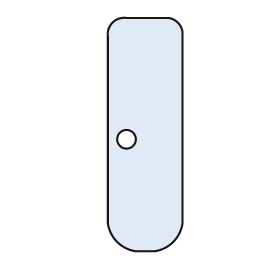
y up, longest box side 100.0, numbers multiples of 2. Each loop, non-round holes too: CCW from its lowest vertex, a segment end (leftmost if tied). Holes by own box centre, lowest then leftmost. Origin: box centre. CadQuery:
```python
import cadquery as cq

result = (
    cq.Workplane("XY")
    .moveTo(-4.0, -50.0)
    .lineTo(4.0, -50.0)
    .threePointArc((12.0, -46.0), (16.0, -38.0))
    .lineTo(16.0, 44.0)
    .threePointArc((14.0, 48.0), (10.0, 50.0))
    .lineTo(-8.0, 50.0)
    .threePointArc((-14.0, 48.0), (-16.0, 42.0))
    .lineTo(-16.0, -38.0)
    .threePointArc((-12.0, -46.0), (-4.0, -50.0))
    .close()
    .moveTo(-8.0, -2.0)
    .circle(4.0)
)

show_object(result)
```